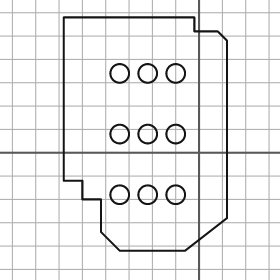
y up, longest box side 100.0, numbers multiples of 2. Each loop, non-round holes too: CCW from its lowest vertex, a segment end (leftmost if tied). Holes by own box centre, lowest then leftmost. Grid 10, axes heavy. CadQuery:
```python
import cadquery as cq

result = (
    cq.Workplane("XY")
    .moveTo(-34.0, -42.0)
    .lineTo(-6.0, -42.0)
    .lineTo(12.0, -28.0)
    .lineTo(12.0, 48.0)
    .lineTo(8.0, 52.0)
    .lineTo(-2.0, 52.0)
    .lineTo(-2.0, 58.0)
    .lineTo(-58.0, 58.0)
    .lineTo(-58.0, -12.0)
    .lineTo(-50.0, -12.0)
    .lineTo(-50.0, -20.0)
    .lineTo(-42.0, -20.0)
    .lineTo(-42.0, -34.0)
    .close()
    .moveTo(-34.0, -18.0)
    .circle(4.0)
    .moveTo(-22.0, -18.0)
    .circle(4.0)
    .moveTo(-10.0, -18.0)
    .circle(4.0)
    .moveTo(-34.0, 8.0)
    .circle(4.0)
    .moveTo(-22.0, 8.0)
    .circle(4.0)
    .moveTo(-10.0, 8.0)
    .circle(4.0)
    .moveTo(-34.0, 34.0)
    .circle(4.0)
    .moveTo(-22.0, 34.0)
    .circle(4.0)
    .moveTo(-10.0, 34.0)
    .circle(4.0)
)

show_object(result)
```